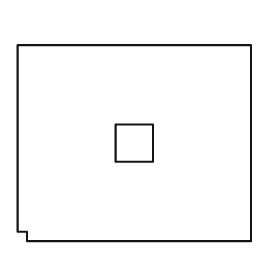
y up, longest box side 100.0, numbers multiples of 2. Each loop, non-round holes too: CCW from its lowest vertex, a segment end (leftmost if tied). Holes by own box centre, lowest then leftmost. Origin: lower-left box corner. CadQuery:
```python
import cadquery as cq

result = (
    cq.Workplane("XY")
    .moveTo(4.0, 0.0)
    .lineTo(100.0, 0.0)
    .lineTo(100.0, 84.0)
    .lineTo(0.0, 84.0)
    .lineTo(0.0, 4.0)
    .lineTo(4.0, 4.0)
    .close()
    .moveTo(42.0, 34.0)
    .lineTo(58.0, 34.0)
    .lineTo(58.0, 50.0)
    .lineTo(42.0, 50.0)
    .close()
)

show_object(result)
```